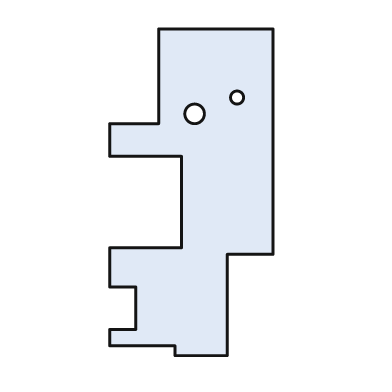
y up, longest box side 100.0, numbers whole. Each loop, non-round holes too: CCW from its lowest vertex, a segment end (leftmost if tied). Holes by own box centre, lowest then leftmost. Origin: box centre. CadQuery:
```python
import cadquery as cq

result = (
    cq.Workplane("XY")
    .moveTo(-5.0, -50.0)
    .lineTo(11.0, -50.0)
    .lineTo(11.0, -19.0)
    .lineTo(25.0, -19.0)
    .lineTo(25.0, 50.0)
    .lineTo(-10.0, 50.0)
    .lineTo(-10.0, 21.0)
    .lineTo(-25.0, 21.0)
    .lineTo(-25.0, 11.0)
    .lineTo(-3.0, 11.0)
    .lineTo(-3.0, -17.0)
    .lineTo(-25.0, -17.0)
    .lineTo(-25.0, -29.0)
    .lineTo(-17.0, -29.0)
    .lineTo(-17.0, -42.0)
    .lineTo(-25.0, -42.0)
    .lineTo(-25.0, -47.0)
    .lineTo(-5.0, -47.0)
    .close()
    .moveTo(1.0, 24.0)
    .circle(3.0)
    .moveTo(14.0, 29.0)
    .circle(2.0)
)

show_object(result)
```